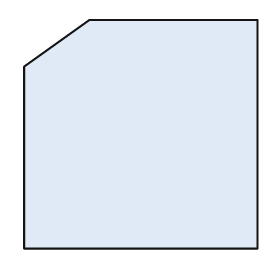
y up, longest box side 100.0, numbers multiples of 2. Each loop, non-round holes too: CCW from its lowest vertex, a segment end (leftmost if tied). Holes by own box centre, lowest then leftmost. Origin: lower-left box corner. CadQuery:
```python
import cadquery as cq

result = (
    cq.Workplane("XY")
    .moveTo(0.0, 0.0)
    .lineTo(100.0, 0.0)
    .lineTo(100.0, 98.0)
    .lineTo(28.0, 98.0)
    .lineTo(0.0, 78.0)
    .close()
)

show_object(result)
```